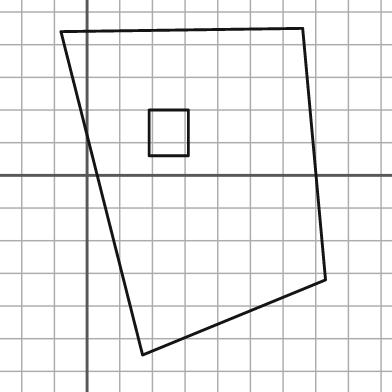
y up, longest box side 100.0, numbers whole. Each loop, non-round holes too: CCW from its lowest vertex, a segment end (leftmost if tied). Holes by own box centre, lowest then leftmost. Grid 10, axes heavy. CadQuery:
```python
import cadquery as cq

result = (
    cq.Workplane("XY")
    .moveTo(17.0, -55.0)
    .lineTo(73.0, -32.0)
    .lineTo(66.0, 45.0)
    .lineTo(-8.0, 44.0)
    .close()
    .moveTo(19.0, 6.0)
    .lineTo(31.0, 6.0)
    .lineTo(31.0, 20.0)
    .lineTo(19.0, 20.0)
    .close()
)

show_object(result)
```